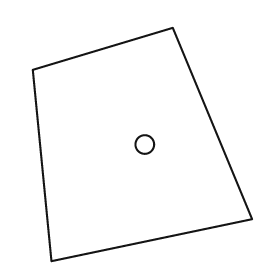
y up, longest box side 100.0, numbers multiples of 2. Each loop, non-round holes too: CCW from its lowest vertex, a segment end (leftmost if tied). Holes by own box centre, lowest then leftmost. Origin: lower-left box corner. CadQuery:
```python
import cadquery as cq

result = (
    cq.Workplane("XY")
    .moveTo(8.0, 0.0)
    .lineTo(94.0, 18.0)
    .lineTo(60.0, 100.0)
    .lineTo(0.0, 82.0)
    .close()
    .moveTo(48.0, 50.0)
    .circle(4.0)
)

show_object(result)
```